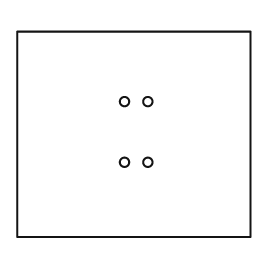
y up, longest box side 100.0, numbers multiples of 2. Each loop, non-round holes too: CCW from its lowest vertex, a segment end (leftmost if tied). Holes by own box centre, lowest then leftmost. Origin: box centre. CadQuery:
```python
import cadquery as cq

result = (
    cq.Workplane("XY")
    .moveTo(-50.0, -44.0)
    .lineTo(50.0, -44.0)
    .lineTo(50.0, 44.0)
    .lineTo(-50.0, 44.0)
    .close()
    .moveTo(-4.0, -12.0)
    .circle(2.0)
    .moveTo(6.0, -12.0)
    .circle(2.0)
    .moveTo(-4.0, 14.0)
    .circle(2.0)
    .moveTo(6.0, 14.0)
    .circle(2.0)
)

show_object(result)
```